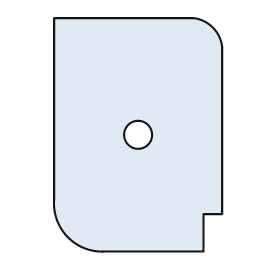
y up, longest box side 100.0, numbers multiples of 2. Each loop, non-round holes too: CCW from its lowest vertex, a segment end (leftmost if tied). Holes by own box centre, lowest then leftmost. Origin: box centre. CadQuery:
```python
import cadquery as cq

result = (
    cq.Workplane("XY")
    .moveTo(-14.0, -50.0)
    .lineTo(28.0, -50.0)
    .lineTo(28.0, -34.0)
    .lineTo(36.0, -34.0)
    .lineTo(36.0, 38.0)
    .threePointArc((32.0, 46.0), (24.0, 50.0))
    .lineTo(-36.0, 50.0)
    .lineTo(-36.0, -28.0)
    .threePointArc((-30.0, -44.0), (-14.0, -50.0))
    .close()
    .moveTo(0.0, 0.0)
    .circle(6.0)
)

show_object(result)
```